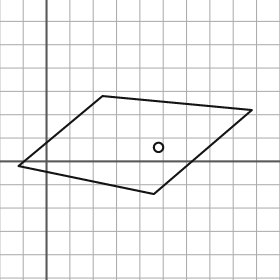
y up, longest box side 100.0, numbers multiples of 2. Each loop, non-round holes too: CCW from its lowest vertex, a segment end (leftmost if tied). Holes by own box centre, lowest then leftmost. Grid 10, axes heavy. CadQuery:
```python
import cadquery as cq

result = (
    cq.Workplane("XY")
    .moveTo(46.0, -14.0)
    .lineTo(88.0, 22.0)
    .lineTo(24.0, 28.0)
    .lineTo(-12.0, -2.0)
    .close()
    .moveTo(48.0, 6.0)
    .circle(2.0)
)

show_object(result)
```